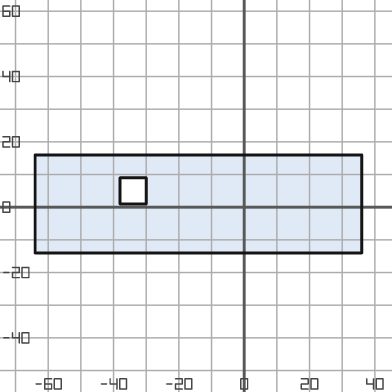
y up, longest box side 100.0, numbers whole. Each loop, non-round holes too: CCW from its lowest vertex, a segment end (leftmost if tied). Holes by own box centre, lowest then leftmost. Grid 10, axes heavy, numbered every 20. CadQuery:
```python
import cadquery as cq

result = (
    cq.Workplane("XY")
    .moveTo(-64.0, -14.0)
    .lineTo(36.0, -14.0)
    .lineTo(36.0, 16.0)
    .lineTo(-64.0, 16.0)
    .close()
    .moveTo(-38.0, 1.0)
    .lineTo(-30.0, 1.0)
    .lineTo(-30.0, 9.0)
    .lineTo(-38.0, 9.0)
    .close()
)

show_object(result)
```